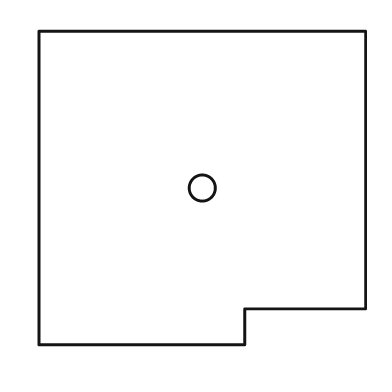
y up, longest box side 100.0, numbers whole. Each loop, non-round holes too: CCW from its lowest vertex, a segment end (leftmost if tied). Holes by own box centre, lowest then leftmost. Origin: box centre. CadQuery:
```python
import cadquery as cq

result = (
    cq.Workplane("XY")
    .moveTo(-50.0, -48.0)
    .lineTo(13.0, -48.0)
    .lineTo(13.0, -37.0)
    .lineTo(50.0, -37.0)
    .lineTo(50.0, 48.0)
    .lineTo(-50.0, 48.0)
    .close()
    .moveTo(0.0, 0.0)
    .circle(4.0)
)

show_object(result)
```